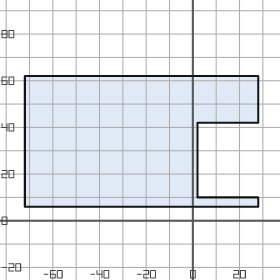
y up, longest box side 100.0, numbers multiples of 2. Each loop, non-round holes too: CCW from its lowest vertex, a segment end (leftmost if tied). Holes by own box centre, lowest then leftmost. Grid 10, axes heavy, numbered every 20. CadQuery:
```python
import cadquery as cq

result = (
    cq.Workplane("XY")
    .moveTo(-72.0, 6.0)
    .lineTo(28.0, 6.0)
    .lineTo(28.0, 10.0)
    .lineTo(2.0, 10.0)
    .lineTo(2.0, 42.0)
    .lineTo(28.0, 42.0)
    .lineTo(28.0, 62.0)
    .lineTo(-72.0, 62.0)
    .close()
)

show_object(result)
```